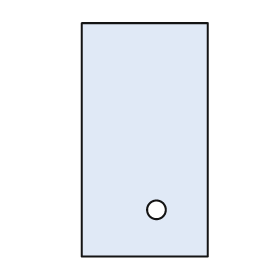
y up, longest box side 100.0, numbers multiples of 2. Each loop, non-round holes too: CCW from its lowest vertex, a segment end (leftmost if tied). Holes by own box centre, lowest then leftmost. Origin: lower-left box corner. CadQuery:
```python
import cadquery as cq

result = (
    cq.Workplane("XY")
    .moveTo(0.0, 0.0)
    .lineTo(54.0, 0.0)
    .lineTo(54.0, 100.0)
    .lineTo(0.0, 100.0)
    .close()
    .moveTo(32.0, 20.0)
    .circle(4.0)
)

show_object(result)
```